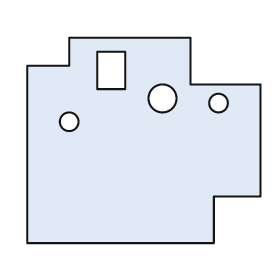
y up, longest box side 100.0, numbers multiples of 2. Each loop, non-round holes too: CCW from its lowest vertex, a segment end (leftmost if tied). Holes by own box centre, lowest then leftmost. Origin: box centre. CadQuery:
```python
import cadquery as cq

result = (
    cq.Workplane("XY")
    .moveTo(-50.0, -44.0)
    .lineTo(30.0, -44.0)
    .lineTo(30.0, -24.0)
    .lineTo(50.0, -24.0)
    .lineTo(50.0, 24.0)
    .lineTo(20.0, 24.0)
    .lineTo(20.0, 44.0)
    .lineTo(-32.0, 44.0)
    .lineTo(-32.0, 32.0)
    .lineTo(-50.0, 32.0)
    .close()
    .moveTo(-32.0, 8.0)
    .circle(4.0)
    .moveTo(32.0, 16.0)
    .circle(4.0)
    .moveTo(8.0, 18.0)
    .circle(6.0)
    .moveTo(-20.0, 22.0)
    .lineTo(-8.0, 22.0)
    .lineTo(-8.0, 38.0)
    .lineTo(-20.0, 38.0)
    .close()
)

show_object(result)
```